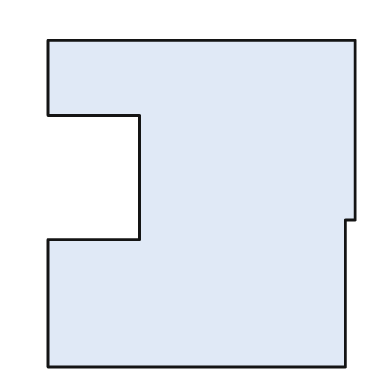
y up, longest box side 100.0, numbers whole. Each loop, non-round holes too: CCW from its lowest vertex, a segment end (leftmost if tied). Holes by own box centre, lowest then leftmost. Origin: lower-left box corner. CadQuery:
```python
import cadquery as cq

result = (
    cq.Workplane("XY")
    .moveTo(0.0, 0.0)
    .lineTo(91.0, 0.0)
    .lineTo(91.0, 45.0)
    .lineTo(94.0, 45.0)
    .lineTo(94.0, 100.0)
    .lineTo(0.0, 100.0)
    .lineTo(0.0, 77.0)
    .lineTo(28.0, 77.0)
    .lineTo(28.0, 39.0)
    .lineTo(0.0, 39.0)
    .close()
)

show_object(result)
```